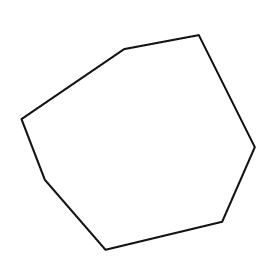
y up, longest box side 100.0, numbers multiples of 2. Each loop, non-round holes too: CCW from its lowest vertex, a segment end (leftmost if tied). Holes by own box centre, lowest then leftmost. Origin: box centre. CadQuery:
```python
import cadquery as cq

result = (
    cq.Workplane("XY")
    .moveTo(-14.0, -46.0)
    .lineTo(36.0, -34.0)
    .lineTo(50.0, -2.0)
    .lineTo(26.0, 46.0)
    .lineTo(-6.0, 40.0)
    .lineTo(-50.0, 10.0)
    .lineTo(-40.0, -16.0)
    .close()
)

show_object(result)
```